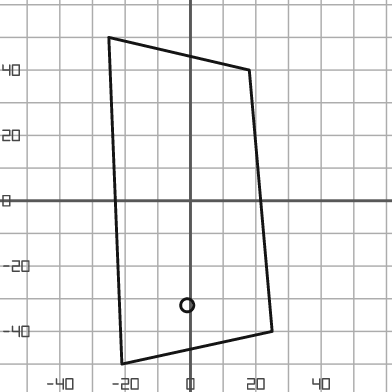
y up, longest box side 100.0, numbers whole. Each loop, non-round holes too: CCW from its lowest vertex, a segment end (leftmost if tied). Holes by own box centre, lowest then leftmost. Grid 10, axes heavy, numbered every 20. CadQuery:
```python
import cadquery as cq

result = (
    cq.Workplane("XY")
    .moveTo(-21.0, -50.0)
    .lineTo(25.0, -40.0)
    .lineTo(18.0, 40.0)
    .lineTo(-25.0, 50.0)
    .close()
    .moveTo(-1.0, -32.0)
    .circle(2.0)
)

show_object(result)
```